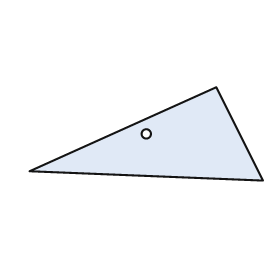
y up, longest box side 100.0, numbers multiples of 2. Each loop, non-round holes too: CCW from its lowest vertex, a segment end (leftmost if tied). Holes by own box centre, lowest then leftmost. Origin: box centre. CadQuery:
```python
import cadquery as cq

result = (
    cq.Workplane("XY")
    .moveTo(50.0, -20.0)
    .lineTo(30.0, 20.0)
    .lineTo(-50.0, -16.0)
    .close()
    .moveTo(0.0, 0.0)
    .circle(2.0)
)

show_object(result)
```